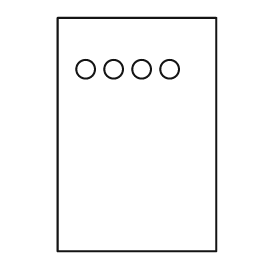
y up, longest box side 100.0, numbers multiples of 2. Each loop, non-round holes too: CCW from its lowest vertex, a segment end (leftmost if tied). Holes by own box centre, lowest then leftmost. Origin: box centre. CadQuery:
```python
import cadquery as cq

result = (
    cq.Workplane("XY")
    .moveTo(-34.0, -50.0)
    .lineTo(34.0, -50.0)
    .lineTo(34.0, 50.0)
    .lineTo(-34.0, 50.0)
    .close()
    .moveTo(-22.0, 28.0)
    .circle(4.0)
    .moveTo(-10.0, 28.0)
    .circle(4.0)
    .moveTo(2.0, 28.0)
    .circle(4.0)
    .moveTo(14.0, 28.0)
    .circle(4.0)
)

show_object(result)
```